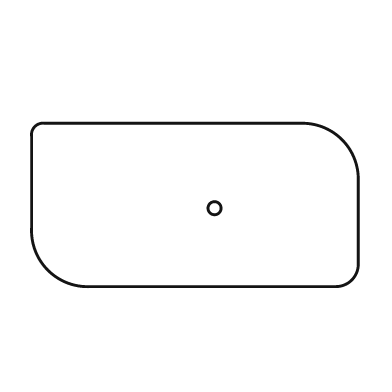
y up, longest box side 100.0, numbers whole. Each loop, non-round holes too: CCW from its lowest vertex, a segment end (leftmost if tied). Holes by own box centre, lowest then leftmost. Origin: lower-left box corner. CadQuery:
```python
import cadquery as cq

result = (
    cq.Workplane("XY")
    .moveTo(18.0, 0.0)
    .lineTo(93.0, 0.0)
    .threePointArc((98.0, 2.0), (100.0, 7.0))
    .lineTo(100.0, 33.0)
    .threePointArc((95.0, 45.0), (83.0, 50.0))
    .lineTo(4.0, 50.0)
    .threePointArc((1.0, 49.0), (0.0, 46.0))
    .lineTo(0.0, 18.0)
    .threePointArc((5.0, 5.0), (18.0, 0.0))
    .close()
    .moveTo(56.0, 24.0)
    .circle(2.0)
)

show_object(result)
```